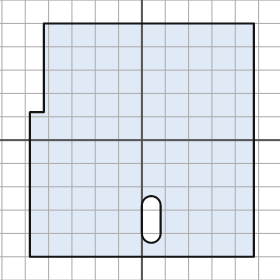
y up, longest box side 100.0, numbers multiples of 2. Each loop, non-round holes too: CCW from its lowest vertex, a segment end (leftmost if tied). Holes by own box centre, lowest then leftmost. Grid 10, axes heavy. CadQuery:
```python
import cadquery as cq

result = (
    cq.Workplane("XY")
    .moveTo(-48.0, -50.0)
    .lineTo(48.0, -50.0)
    .lineTo(48.0, 50.0)
    .lineTo(-42.0, 50.0)
    .lineTo(-42.0, 12.0)
    .lineTo(-48.0, 12.0)
    .close()
    .moveTo(0.0, -40.0)
    .threePointArc((4.0, -44.0), (8.0, -40.0))
    .lineTo(8.0, -28.0)
    .threePointArc((4.0, -24.0), (0.0, -28.0))
    .close()
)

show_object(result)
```